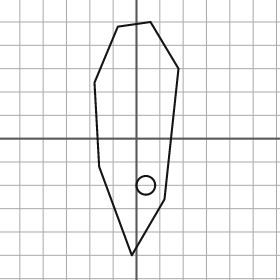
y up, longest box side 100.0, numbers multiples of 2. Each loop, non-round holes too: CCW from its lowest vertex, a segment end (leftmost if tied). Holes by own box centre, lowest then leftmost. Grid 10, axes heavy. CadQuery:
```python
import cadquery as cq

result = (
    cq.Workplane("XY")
    .moveTo(-2.0, -50.0)
    .lineTo(12.0, -26.0)
    .lineTo(18.0, 30.0)
    .lineTo(6.0, 50.0)
    .lineTo(-8.0, 48.0)
    .lineTo(-18.0, 24.0)
    .lineTo(-16.0, -12.0)
    .close()
    .moveTo(4.0, -20.0)
    .circle(4.0)
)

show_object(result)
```